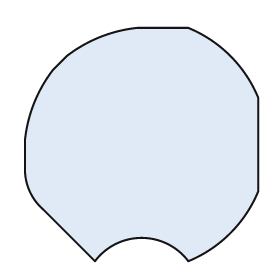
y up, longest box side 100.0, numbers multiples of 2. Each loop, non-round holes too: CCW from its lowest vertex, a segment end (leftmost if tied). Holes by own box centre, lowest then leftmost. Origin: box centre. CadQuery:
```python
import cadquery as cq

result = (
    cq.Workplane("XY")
    .moveTo(-20.0, -50.0)
    .threePointArc((0.0, -40.0), (20.0, -50.0))
    .threePointArc((38.0, -38.0), (50.0, -20.0))
    .lineTo(50.0, 20.0)
    .threePointArc((38.0, 38.0), (20.0, 50.0))
    .lineTo(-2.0, 50.0)
    .threePointArc((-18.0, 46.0), (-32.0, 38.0))
    .lineTo(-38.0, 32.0)
    .threePointArc((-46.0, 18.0), (-50.0, 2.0))
    .lineTo(-50.0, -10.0)
    .threePointArc((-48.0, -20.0), (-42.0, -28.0))
    .close()
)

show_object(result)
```